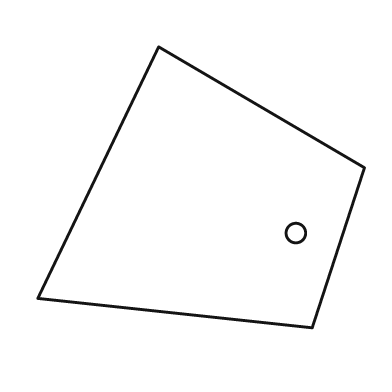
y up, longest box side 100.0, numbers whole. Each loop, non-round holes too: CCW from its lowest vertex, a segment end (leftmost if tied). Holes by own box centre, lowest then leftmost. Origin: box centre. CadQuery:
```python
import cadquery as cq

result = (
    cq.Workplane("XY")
    .moveTo(34.0, -43.0)
    .lineTo(50.0, 6.0)
    .lineTo(-13.0, 43.0)
    .lineTo(-50.0, -34.0)
    .close()
    .moveTo(29.0, -14.0)
    .circle(3.0)
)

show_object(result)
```